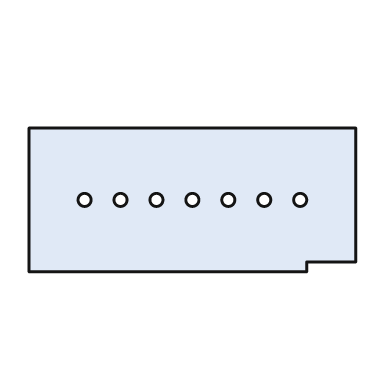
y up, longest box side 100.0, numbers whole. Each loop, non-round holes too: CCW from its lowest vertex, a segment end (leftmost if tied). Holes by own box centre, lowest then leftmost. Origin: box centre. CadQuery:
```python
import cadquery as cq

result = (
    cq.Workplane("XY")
    .moveTo(-50.0, -22.0)
    .lineTo(35.0, -22.0)
    .lineTo(35.0, -19.0)
    .lineTo(50.0, -19.0)
    .lineTo(50.0, 22.0)
    .lineTo(-50.0, 22.0)
    .close()
    .moveTo(-33.0, 0.0)
    .circle(2.0)
    .moveTo(-22.0, 0.0)
    .circle(2.0)
    .moveTo(-11.0, 0.0)
    .circle(2.0)
    .moveTo(0.0, 0.0)
    .circle(2.0)
    .moveTo(11.0, 0.0)
    .circle(2.0)
    .moveTo(22.0, 0.0)
    .circle(2.0)
    .moveTo(33.0, 0.0)
    .circle(2.0)
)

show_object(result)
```